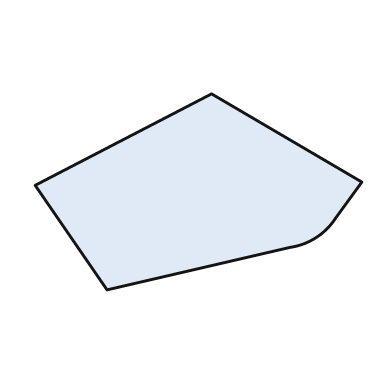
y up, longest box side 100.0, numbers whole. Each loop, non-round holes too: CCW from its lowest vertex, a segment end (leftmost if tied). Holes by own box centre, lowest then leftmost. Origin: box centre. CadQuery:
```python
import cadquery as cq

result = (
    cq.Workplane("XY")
    .moveTo(-28.0, -30.0)
    .lineTo(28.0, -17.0)
    .threePointArc((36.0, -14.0), (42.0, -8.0))
    .lineTo(50.0, 3.0)
    .lineTo(4.0, 30.0)
    .lineTo(-50.0, 2.0)
    .close()
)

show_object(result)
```